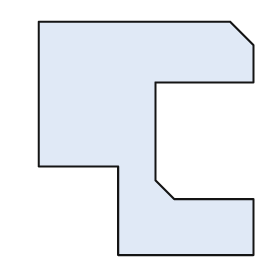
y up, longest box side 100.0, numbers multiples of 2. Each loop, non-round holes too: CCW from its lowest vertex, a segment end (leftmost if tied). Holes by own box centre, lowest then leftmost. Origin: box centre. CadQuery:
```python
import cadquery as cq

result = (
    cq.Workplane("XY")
    .moveTo(-12.0, -50.0)
    .lineTo(46.0, -50.0)
    .lineTo(46.0, -26.0)
    .lineTo(12.0, -26.0)
    .lineTo(4.0, -18.0)
    .lineTo(4.0, 24.0)
    .lineTo(46.0, 24.0)
    .lineTo(46.0, 40.0)
    .lineTo(36.0, 50.0)
    .lineTo(-46.0, 50.0)
    .lineTo(-46.0, -12.0)
    .lineTo(-12.0, -12.0)
    .close()
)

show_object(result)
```